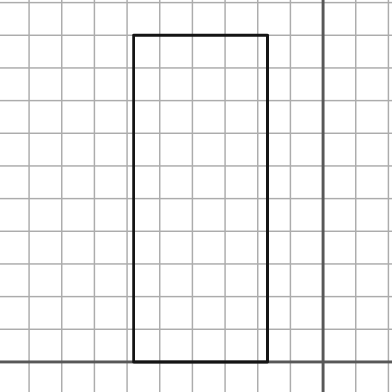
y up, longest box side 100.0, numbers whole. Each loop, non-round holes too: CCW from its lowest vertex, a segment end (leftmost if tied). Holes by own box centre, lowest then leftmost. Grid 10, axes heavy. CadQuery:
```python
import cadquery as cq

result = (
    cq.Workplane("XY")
    .moveTo(-58.0, 0.0)
    .lineTo(-17.0, 0.0)
    .lineTo(-17.0, 100.0)
    .lineTo(-58.0, 100.0)
    .close()
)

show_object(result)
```